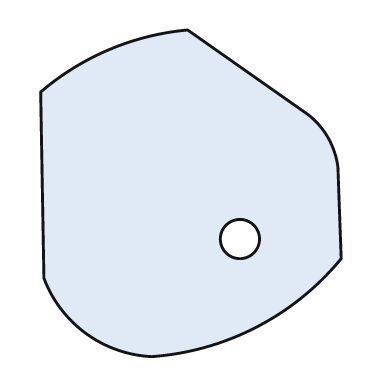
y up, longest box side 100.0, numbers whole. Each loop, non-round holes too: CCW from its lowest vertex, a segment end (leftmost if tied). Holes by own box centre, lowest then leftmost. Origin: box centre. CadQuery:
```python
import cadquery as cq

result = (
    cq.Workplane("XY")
    .moveTo(-12.0, -50.0)
    .threePointArc((20.0, -41.0), (46.0, -20.0))
    .lineTo(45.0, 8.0)
    .threePointArc((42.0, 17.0), (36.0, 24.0))
    .lineTo(-1.0, 50.0)
    .threePointArc((-25.0, 44.0), (-46.0, 31.0))
    .lineTo(-45.0, -26.0)
    .threePointArc((-32.0, -43.0), (-12.0, -50.0))
    .close()
    .moveTo(15.0, -14.0)
    .circle(6.0)
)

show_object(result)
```